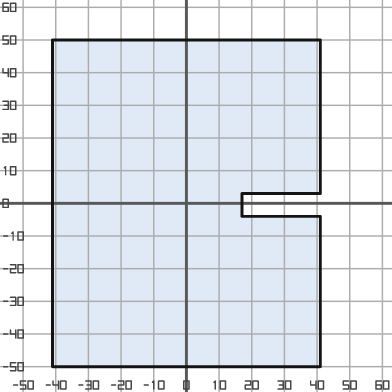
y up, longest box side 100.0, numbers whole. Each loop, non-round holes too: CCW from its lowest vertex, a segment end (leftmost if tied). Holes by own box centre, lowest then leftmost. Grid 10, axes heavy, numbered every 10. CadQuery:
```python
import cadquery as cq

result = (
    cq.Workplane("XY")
    .moveTo(-41.0, -50.0)
    .lineTo(41.0, -50.0)
    .lineTo(41.0, -4.0)
    .lineTo(17.0, -4.0)
    .lineTo(17.0, 3.0)
    .lineTo(41.0, 3.0)
    .lineTo(41.0, 50.0)
    .lineTo(-41.0, 50.0)
    .close()
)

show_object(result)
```